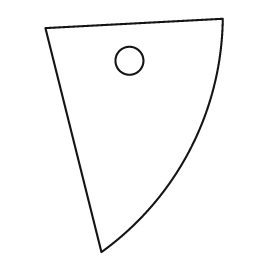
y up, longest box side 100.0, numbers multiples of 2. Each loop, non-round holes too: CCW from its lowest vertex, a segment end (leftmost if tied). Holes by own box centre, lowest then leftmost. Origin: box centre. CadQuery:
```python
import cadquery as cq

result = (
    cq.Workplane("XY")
    .moveTo(-14.0, -50.0)
    .threePointArc((24.0, -6.0), (38.0, 50.0))
    .lineTo(-38.0, 46.0)
    .close()
    .moveTo(-2.0, 32.0)
    .circle(6.0)
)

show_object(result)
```